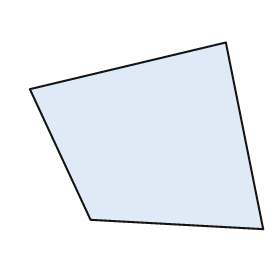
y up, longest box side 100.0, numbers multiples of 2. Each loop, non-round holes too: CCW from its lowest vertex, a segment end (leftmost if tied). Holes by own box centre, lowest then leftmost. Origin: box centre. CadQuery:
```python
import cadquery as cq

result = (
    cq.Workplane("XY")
    .moveTo(50.0, -40.0)
    .lineTo(34.0, 40.0)
    .lineTo(-50.0, 20.0)
    .lineTo(-24.0, -36.0)
    .close()
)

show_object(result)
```